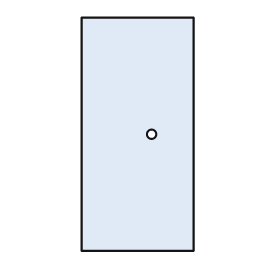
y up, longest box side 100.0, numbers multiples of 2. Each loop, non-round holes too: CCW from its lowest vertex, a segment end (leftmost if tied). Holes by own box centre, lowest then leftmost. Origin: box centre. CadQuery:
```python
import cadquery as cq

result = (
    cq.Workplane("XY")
    .moveTo(-24.0, -50.0)
    .lineTo(24.0, -50.0)
    .lineTo(24.0, 50.0)
    .lineTo(-24.0, 50.0)
    .close()
    .moveTo(6.0, 0.0)
    .circle(2.0)
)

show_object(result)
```